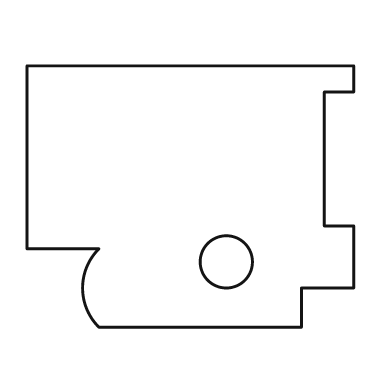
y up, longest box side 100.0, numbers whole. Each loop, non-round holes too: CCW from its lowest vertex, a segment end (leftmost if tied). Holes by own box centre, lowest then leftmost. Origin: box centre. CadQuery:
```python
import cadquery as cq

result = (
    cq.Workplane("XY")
    .moveTo(-28.0, -40.0)
    .lineTo(34.0, -40.0)
    .lineTo(34.0, -28.0)
    .lineTo(50.0, -28.0)
    .lineTo(50.0, -9.0)
    .lineTo(41.0, -9.0)
    .lineTo(41.0, 32.0)
    .lineTo(50.0, 32.0)
    .lineTo(50.0, 40.0)
    .lineTo(-50.0, 40.0)
    .lineTo(-50.0, -16.0)
    .lineTo(-28.0, -16.0)
    .threePointArc((-33.0, -28.0), (-28.0, -40.0))
    .close()
    .moveTo(11.0, -20.0)
    .circle(8.0)
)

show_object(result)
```